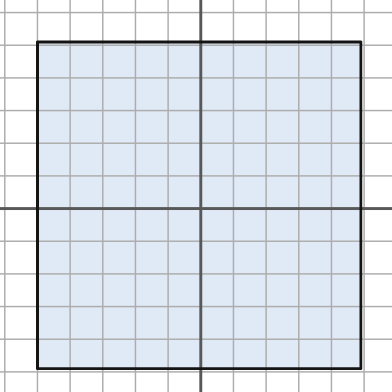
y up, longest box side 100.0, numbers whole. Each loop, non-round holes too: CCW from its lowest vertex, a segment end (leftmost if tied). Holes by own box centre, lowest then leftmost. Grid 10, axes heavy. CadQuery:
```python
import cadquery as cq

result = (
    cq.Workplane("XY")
    .moveTo(-50.0, -49.0)
    .lineTo(49.0, -49.0)
    .lineTo(49.0, 51.0)
    .lineTo(-50.0, 51.0)
    .close()
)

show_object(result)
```